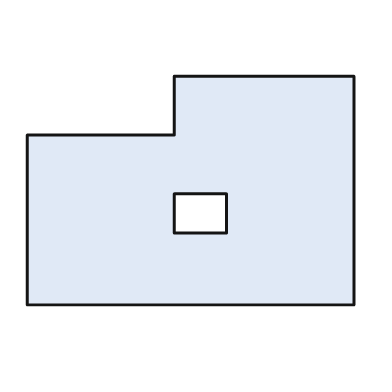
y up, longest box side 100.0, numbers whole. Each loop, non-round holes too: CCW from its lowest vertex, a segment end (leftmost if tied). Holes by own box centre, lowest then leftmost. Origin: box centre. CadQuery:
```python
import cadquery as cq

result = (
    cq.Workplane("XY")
    .moveTo(-50.0, -35.0)
    .lineTo(50.0, -35.0)
    .lineTo(50.0, 35.0)
    .lineTo(-5.0, 35.0)
    .lineTo(-5.0, 17.0)
    .lineTo(-50.0, 17.0)
    .close()
    .moveTo(-5.0, -13.0)
    .lineTo(11.0, -13.0)
    .lineTo(11.0, -1.0)
    .lineTo(-5.0, -1.0)
    .close()
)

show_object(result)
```